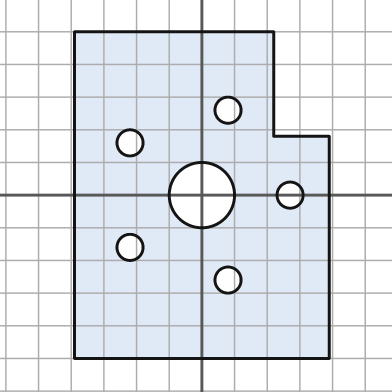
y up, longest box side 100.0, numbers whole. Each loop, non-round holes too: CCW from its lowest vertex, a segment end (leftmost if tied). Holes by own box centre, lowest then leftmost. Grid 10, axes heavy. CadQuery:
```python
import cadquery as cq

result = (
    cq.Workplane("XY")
    .moveTo(-39.0, -50.0)
    .lineTo(39.0, -50.0)
    .lineTo(39.0, 18.0)
    .lineTo(22.0, 18.0)
    .lineTo(22.0, 50.0)
    .lineTo(-39.0, 50.0)
    .close()
    .moveTo(8.0, -26.0)
    .circle(4.0)
    .moveTo(-22.0, -16.0)
    .circle(4.0)
    .moveTo(0.0, 0.0)
    .circle(10.0)
    .moveTo(27.0, 0.0)
    .circle(4.0)
    .moveTo(-22.0, 16.0)
    .circle(4.0)
    .moveTo(8.0, 26.0)
    .circle(4.0)
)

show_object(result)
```